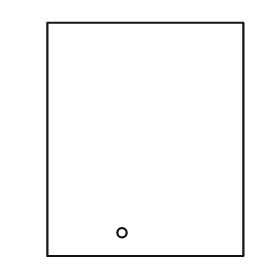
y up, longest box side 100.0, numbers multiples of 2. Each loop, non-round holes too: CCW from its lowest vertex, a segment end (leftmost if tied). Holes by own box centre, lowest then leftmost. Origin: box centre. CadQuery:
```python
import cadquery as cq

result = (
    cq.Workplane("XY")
    .moveTo(-42.0, -50.0)
    .lineTo(42.0, -50.0)
    .lineTo(42.0, 50.0)
    .lineTo(-42.0, 50.0)
    .close()
    .moveTo(-10.0, -40.0)
    .circle(2.0)
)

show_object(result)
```